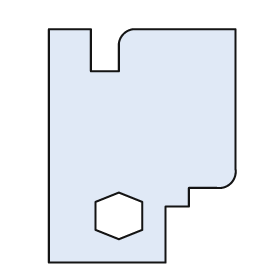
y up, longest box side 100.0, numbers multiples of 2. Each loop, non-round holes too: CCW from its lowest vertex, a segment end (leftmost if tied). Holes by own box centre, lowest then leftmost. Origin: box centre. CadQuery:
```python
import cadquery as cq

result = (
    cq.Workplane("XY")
    .moveTo(-40.0, -50.0)
    .lineTo(10.0, -50.0)
    .lineTo(10.0, -26.0)
    .lineTo(20.0, -26.0)
    .lineTo(20.0, -18.0)
    .lineTo(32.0, -18.0)
    .threePointArc((38.0, -16.0), (40.0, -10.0))
    .lineTo(40.0, 50.0)
    .lineTo(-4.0, 50.0)
    .threePointArc((-8.0, 48.0), (-10.0, 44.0))
    .lineTo(-10.0, 32.0)
    .lineTo(-22.0, 32.0)
    .lineTo(-22.0, 50.0)
    .lineTo(-40.0, 50.0)
    .close()
    .moveTo(-10.0, -40.0)
    .lineTo(0.0, -36.0)
    .lineTo(0.0, -24.0)
    .lineTo(-10.0, -20.0)
    .lineTo(-20.0, -24.0)
    .lineTo(-20.0, -36.0)
    .close()
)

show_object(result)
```